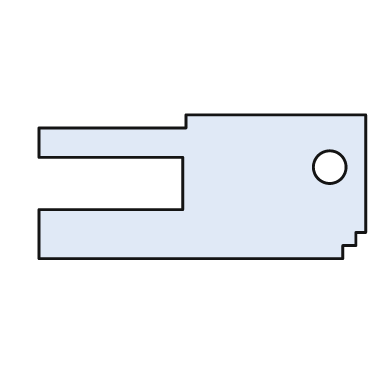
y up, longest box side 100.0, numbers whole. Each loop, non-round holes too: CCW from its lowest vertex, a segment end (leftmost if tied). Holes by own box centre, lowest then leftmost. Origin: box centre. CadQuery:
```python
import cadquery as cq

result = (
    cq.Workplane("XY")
    .moveTo(-50.0, -22.0)
    .lineTo(43.0, -22.0)
    .lineTo(43.0, -18.0)
    .lineTo(47.0, -18.0)
    .lineTo(47.0, -14.0)
    .lineTo(50.0, -14.0)
    .lineTo(50.0, 22.0)
    .lineTo(-5.0, 22.0)
    .lineTo(-5.0, 18.0)
    .lineTo(-50.0, 18.0)
    .lineTo(-50.0, 9.0)
    .lineTo(-6.0, 9.0)
    .lineTo(-6.0, -7.0)
    .lineTo(-50.0, -7.0)
    .close()
    .moveTo(39.0, 6.0)
    .circle(5.0)
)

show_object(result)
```